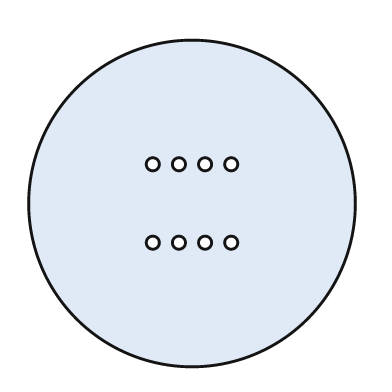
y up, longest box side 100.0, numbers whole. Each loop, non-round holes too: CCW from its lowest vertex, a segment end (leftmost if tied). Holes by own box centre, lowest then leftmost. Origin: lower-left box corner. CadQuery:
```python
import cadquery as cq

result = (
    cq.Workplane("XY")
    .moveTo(50.0, 50.0)
    .circle(50.0)
    .moveTo(38.0, 38.0)
    .circle(2.0)
    .moveTo(46.0, 38.0)
    .circle(2.0)
    .moveTo(54.0, 38.0)
    .circle(2.0)
    .moveTo(62.0, 38.0)
    .circle(2.0)
    .moveTo(38.0, 62.0)
    .circle(2.0)
    .moveTo(46.0, 62.0)
    .circle(2.0)
    .moveTo(54.0, 62.0)
    .circle(2.0)
    .moveTo(62.0, 62.0)
    .circle(2.0)
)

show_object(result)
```